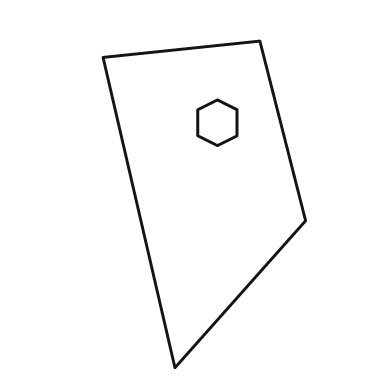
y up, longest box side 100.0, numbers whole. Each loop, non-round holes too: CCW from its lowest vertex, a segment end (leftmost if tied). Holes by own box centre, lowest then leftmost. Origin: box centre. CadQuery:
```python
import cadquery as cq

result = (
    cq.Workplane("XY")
    .moveTo(-9.0, -50.0)
    .lineTo(31.0, -5.0)
    .lineTo(17.0, 50.0)
    .lineTo(-31.0, 45.0)
    .close()
    .moveTo(4.0, 18.0)
    .lineTo(10.0, 21.0)
    .lineTo(10.0, 29.0)
    .lineTo(4.0, 32.0)
    .lineTo(-2.0, 29.0)
    .lineTo(-2.0, 21.0)
    .close()
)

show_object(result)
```